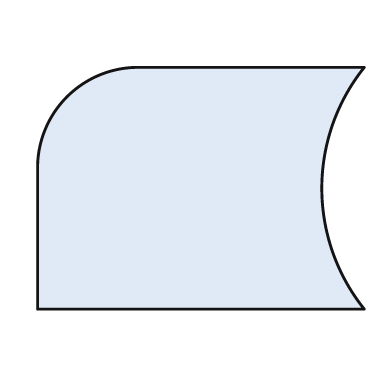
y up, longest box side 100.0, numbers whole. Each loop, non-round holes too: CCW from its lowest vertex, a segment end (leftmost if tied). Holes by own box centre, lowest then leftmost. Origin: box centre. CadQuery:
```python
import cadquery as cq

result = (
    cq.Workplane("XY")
    .moveTo(-50.0, -37.0)
    .lineTo(50.0, -37.0)
    .threePointArc((37.0, 0.0), (50.0, 37.0))
    .lineTo(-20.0, 37.0)
    .threePointArc((-41.0, 28.0), (-50.0, 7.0))
    .close()
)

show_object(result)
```